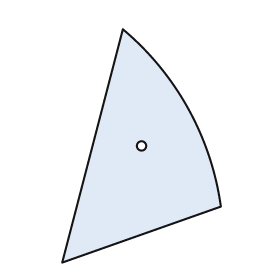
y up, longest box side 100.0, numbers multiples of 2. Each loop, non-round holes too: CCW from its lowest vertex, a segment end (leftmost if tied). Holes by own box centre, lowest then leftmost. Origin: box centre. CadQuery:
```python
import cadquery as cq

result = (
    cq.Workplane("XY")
    .moveTo(-34.0, -50.0)
    .lineTo(34.0, -26.0)
    .threePointArc((20.0, 16.0), (-8.0, 50.0))
    .close()
    .moveTo(0.0, 0.0)
    .circle(2.0)
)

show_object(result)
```